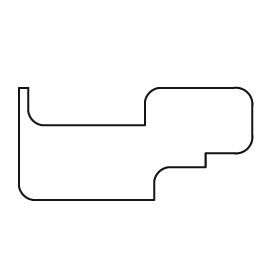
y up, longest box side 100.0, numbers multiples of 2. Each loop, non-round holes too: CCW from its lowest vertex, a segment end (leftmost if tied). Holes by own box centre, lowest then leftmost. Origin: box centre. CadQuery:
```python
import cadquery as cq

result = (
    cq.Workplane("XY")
    .moveTo(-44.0, -24.0)
    .lineTo(8.0, -24.0)
    .lineTo(8.0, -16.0)
    .threePointArc((10.0, -12.0), (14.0, -10.0))
    .lineTo(30.0, -10.0)
    .lineTo(30.0, -4.0)
    .lineTo(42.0, -4.0)
    .threePointArc((48.0, -2.0), (50.0, 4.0))
    .lineTo(50.0, 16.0)
    .threePointArc((48.0, 22.0), (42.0, 24.0))
    .lineTo(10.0, 24.0)
    .threePointArc((6.0, 22.0), (4.0, 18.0))
    .lineTo(4.0, 8.0)
    .lineTo(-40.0, 8.0)
    .threePointArc((-44.0, 10.0), (-46.0, 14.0))
    .lineTo(-46.0, 24.0)
    .lineTo(-50.0, 24.0)
    .lineTo(-50.0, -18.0)
    .threePointArc((-48.0, -22.0), (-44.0, -24.0))
    .close()
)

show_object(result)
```